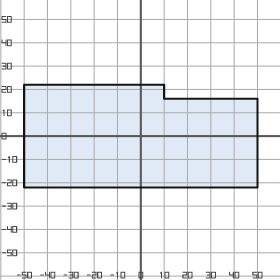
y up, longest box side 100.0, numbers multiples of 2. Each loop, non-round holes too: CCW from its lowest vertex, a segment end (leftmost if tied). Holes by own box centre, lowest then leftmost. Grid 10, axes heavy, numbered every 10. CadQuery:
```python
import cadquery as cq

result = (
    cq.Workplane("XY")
    .moveTo(-50.0, -22.0)
    .lineTo(50.0, -22.0)
    .lineTo(50.0, 16.0)
    .lineTo(10.0, 16.0)
    .lineTo(10.0, 22.0)
    .lineTo(-50.0, 22.0)
    .close()
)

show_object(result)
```